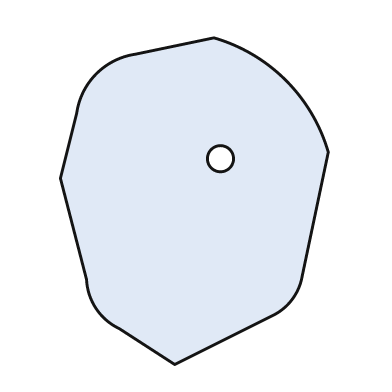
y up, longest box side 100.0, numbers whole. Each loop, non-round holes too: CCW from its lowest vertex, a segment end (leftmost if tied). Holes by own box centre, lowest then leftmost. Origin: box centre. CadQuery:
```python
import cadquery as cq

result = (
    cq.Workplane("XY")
    .moveTo(-6.0, -50.0)
    .lineTo(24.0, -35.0)
    .threePointArc((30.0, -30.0), (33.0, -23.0))
    .lineTo(41.0, 15.0)
    .threePointArc((28.0, 37.0), (6.0, 50.0))
    .lineTo(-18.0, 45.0)
    .threePointArc((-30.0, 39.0), (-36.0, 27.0))
    .lineTo(-41.0, 7.0)
    .lineTo(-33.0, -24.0)
    .threePointArc((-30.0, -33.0), (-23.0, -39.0))
    .close()
    .moveTo(8.0, 13.0)
    .circle(4.0)
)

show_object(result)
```